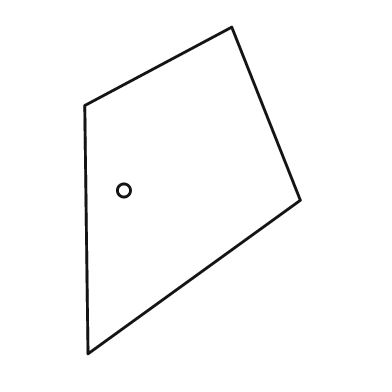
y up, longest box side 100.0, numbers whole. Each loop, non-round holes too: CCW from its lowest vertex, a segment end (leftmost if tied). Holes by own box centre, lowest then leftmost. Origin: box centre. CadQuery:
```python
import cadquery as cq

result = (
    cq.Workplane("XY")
    .moveTo(-32.0, -50.0)
    .lineTo(33.0, -3.0)
    .lineTo(12.0, 50.0)
    .lineTo(-33.0, 26.0)
    .close()
    .moveTo(-21.0, 0.0)
    .circle(2.0)
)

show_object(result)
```